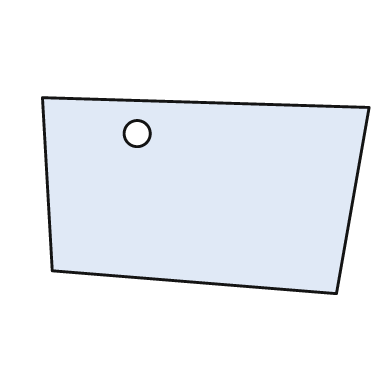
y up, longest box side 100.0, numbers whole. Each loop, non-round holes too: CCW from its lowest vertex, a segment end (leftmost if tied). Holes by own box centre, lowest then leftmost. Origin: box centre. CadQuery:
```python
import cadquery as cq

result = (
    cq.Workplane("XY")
    .moveTo(40.0, -30.0)
    .lineTo(50.0, 27.0)
    .lineTo(-50.0, 30.0)
    .lineTo(-47.0, -23.0)
    .close()
    .moveTo(-21.0, 19.0)
    .circle(4.0)
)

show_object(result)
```